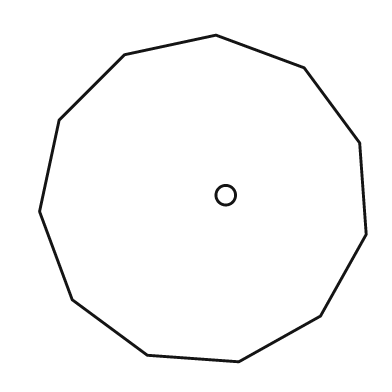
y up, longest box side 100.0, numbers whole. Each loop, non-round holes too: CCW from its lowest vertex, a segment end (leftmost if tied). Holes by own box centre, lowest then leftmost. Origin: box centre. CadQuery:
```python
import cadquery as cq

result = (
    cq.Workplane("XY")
    .moveTo(11.0, -50.0)
    .lineTo(36.0, -36.0)
    .lineTo(50.0, -11.0)
    .lineTo(48.0, 17.0)
    .lineTo(31.0, 40.0)
    .lineTo(4.0, 50.0)
    .lineTo(-24.0, 44.0)
    .lineTo(-44.0, 24.0)
    .lineTo(-50.0, -4.0)
    .lineTo(-40.0, -31.0)
    .lineTo(-17.0, -48.0)
    .close()
    .moveTo(7.0, 1.0)
    .circle(3.0)
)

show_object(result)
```